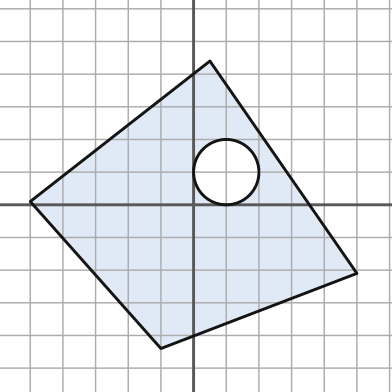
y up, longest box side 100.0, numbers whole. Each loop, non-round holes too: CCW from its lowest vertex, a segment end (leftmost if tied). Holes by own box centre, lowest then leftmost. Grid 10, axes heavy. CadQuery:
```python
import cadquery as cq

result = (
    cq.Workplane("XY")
    .moveTo(-10.0, -44.0)
    .lineTo(50.0, -21.0)
    .lineTo(5.0, 44.0)
    .lineTo(-50.0, 1.0)
    .close()
    .moveTo(10.0, 10.0)
    .circle(10.0)
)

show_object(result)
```